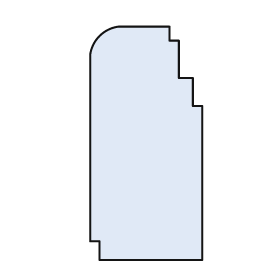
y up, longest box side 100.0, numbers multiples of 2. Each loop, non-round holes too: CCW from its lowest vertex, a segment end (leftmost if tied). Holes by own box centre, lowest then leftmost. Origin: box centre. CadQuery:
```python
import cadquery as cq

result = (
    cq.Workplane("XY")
    .moveTo(-20.0, -50.0)
    .lineTo(24.0, -50.0)
    .lineTo(24.0, 16.0)
    .lineTo(20.0, 16.0)
    .lineTo(20.0, 28.0)
    .lineTo(14.0, 28.0)
    .lineTo(14.0, 44.0)
    .lineTo(10.0, 44.0)
    .lineTo(10.0, 50.0)
    .lineTo(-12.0, 50.0)
    .threePointArc((-20.0, 46.0), (-24.0, 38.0))
    .lineTo(-24.0, -42.0)
    .lineTo(-20.0, -42.0)
    .close()
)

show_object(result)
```